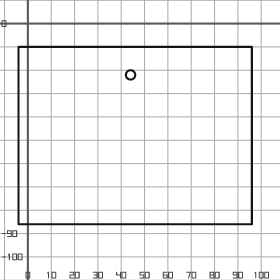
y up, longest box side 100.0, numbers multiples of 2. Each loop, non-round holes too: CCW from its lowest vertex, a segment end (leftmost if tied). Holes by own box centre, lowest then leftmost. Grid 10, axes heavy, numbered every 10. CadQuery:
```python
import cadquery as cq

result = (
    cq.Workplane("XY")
    .moveTo(-4.0, -86.0)
    .lineTo(96.0, -86.0)
    .lineTo(96.0, -10.0)
    .lineTo(-4.0, -10.0)
    .close()
    .moveTo(44.0, -22.0)
    .circle(2.0)
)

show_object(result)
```